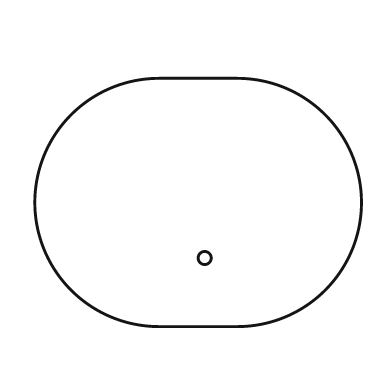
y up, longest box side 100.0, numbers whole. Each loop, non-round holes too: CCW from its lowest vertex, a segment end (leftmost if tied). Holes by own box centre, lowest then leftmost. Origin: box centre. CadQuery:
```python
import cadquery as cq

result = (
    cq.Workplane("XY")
    .moveTo(-12.0, -38.0)
    .lineTo(12.0, -38.0)
    .threePointArc((50.0, 0.0), (12.0, 38.0))
    .lineTo(-12.0, 38.0)
    .threePointArc((-50.0, 0.0), (-12.0, -38.0))
    .close()
    .moveTo(2.0, -17.0)
    .circle(2.0)
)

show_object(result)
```